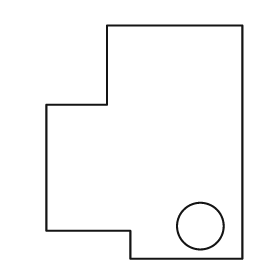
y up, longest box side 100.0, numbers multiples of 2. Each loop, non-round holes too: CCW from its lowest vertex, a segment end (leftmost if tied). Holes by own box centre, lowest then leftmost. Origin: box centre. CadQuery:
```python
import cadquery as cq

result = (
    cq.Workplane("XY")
    .moveTo(-6.0, -50.0)
    .lineTo(42.0, -50.0)
    .lineTo(42.0, 50.0)
    .lineTo(-16.0, 50.0)
    .lineTo(-16.0, 16.0)
    .lineTo(-42.0, 16.0)
    .lineTo(-42.0, -38.0)
    .lineTo(-6.0, -38.0)
    .close()
    .moveTo(24.0, -36.0)
    .circle(10.0)
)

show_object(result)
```